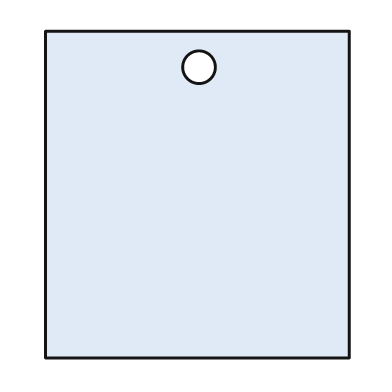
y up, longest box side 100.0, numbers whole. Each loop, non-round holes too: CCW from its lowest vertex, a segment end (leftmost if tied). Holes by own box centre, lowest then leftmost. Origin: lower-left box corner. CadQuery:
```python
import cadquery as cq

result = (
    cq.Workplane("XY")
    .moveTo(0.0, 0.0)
    .lineTo(93.0, 0.0)
    .lineTo(93.0, 100.0)
    .lineTo(0.0, 100.0)
    .close()
    .moveTo(47.0, 89.0)
    .circle(5.0)
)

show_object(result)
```